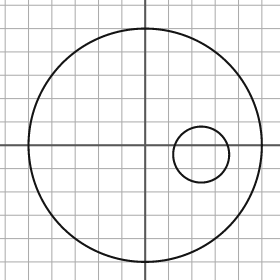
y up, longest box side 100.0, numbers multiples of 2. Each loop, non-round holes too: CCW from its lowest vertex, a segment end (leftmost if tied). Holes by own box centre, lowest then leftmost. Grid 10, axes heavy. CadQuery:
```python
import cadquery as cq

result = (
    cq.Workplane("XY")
    .moveTo(0.0, 0.0)
    .circle(50.0)
    .moveTo(24.0, -4.0)
    .circle(12.0)
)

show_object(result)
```